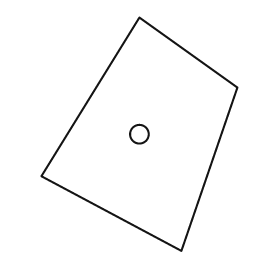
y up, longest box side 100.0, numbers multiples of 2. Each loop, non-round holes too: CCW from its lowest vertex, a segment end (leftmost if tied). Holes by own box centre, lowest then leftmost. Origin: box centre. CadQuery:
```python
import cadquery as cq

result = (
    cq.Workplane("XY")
    .moveTo(18.0, -50.0)
    .lineTo(42.0, 20.0)
    .lineTo(0.0, 50.0)
    .lineTo(-42.0, -18.0)
    .close()
    .moveTo(0.0, 0.0)
    .circle(4.0)
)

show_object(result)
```